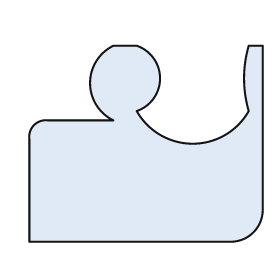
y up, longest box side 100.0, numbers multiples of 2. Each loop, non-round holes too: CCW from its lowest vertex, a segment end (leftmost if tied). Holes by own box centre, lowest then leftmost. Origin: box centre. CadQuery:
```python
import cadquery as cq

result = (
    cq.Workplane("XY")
    .moveTo(-50.0, -42.0)
    .lineTo(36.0, -42.0)
    .threePointArc((46.0, -38.0), (50.0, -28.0))
    .lineTo(50.0, 42.0)
    .lineTo(44.0, 42.0)
    .threePointArc((42.0, 28.0), (44.0, 14.0))
    .threePointArc((20.0, 0.0), (-4.0, 14.0))
    .threePointArc((6.0, 28.0), (-4.0, 42.0))
    .lineTo(-14.0, 42.0)
    .threePointArc((-24.0, 26.0), (-14.0, 10.0))
    .lineTo(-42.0, 10.0)
    .threePointArc((-48.0, 8.0), (-50.0, 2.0))
    .close()
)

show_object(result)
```